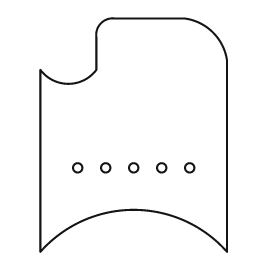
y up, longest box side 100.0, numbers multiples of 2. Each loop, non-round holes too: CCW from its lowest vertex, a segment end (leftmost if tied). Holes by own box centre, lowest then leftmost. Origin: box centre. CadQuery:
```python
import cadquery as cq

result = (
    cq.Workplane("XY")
    .moveTo(-40.0, -50.0)
    .threePointArc((0.0, -32.0), (40.0, -50.0))
    .lineTo(40.0, 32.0)
    .threePointArc((34.0, 44.0), (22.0, 50.0))
    .lineTo(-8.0, 50.0)
    .threePointArc((-14.0, 48.0), (-16.0, 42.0))
    .lineTo(-16.0, 28.0)
    .threePointArc((-28.0, 22.0), (-40.0, 28.0))
    .close()
    .moveTo(-24.0, -14.0)
    .circle(2.0)
    .moveTo(-12.0, -14.0)
    .circle(2.0)
    .moveTo(0.0, -14.0)
    .circle(2.0)
    .moveTo(12.0, -14.0)
    .circle(2.0)
    .moveTo(24.0, -14.0)
    .circle(2.0)
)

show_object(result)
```